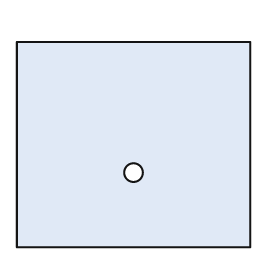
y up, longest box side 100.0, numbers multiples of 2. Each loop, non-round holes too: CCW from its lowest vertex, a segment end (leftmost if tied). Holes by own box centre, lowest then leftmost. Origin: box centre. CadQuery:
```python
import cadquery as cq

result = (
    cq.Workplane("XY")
    .moveTo(-50.0, -44.0)
    .lineTo(50.0, -44.0)
    .lineTo(50.0, 44.0)
    .lineTo(-50.0, 44.0)
    .close()
    .moveTo(0.0, -12.0)
    .circle(4.0)
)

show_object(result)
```